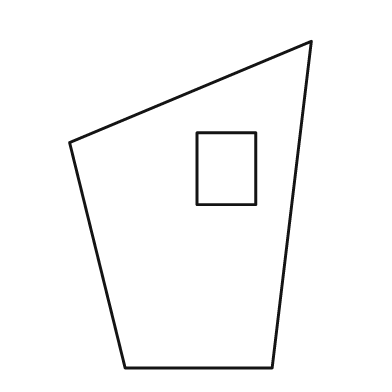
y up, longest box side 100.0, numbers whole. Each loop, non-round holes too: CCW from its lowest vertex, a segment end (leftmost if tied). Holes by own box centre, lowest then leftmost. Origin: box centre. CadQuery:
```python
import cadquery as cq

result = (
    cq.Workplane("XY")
    .moveTo(-20.0, -50.0)
    .lineTo(25.0, -50.0)
    .lineTo(37.0, 50.0)
    .lineTo(-37.0, 19.0)
    .close()
    .moveTo(2.0, 0.0)
    .lineTo(20.0, 0.0)
    .lineTo(20.0, 22.0)
    .lineTo(2.0, 22.0)
    .close()
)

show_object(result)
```